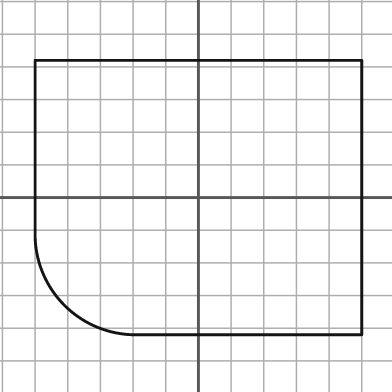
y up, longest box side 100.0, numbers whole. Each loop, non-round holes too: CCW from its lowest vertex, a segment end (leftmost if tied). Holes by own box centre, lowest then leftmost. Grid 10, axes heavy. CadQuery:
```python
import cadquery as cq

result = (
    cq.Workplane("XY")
    .moveTo(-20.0, -42.0)
    .lineTo(50.0, -42.0)
    .lineTo(50.0, 42.0)
    .lineTo(-50.0, 42.0)
    .lineTo(-50.0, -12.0)
    .threePointArc((-41.0, -33.0), (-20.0, -42.0))
    .close()
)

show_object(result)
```